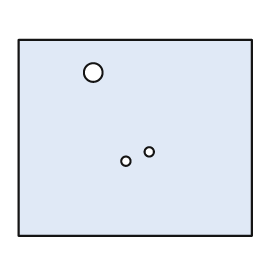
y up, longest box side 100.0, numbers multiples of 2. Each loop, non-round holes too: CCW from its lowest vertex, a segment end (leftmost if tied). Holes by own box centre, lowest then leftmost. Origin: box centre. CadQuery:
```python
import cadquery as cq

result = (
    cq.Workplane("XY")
    .moveTo(-50.0, -42.0)
    .lineTo(50.0, -42.0)
    .lineTo(50.0, 42.0)
    .lineTo(-50.0, 42.0)
    .close()
    .moveTo(-4.0, -10.0)
    .circle(2.0)
    .moveTo(6.0, -6.0)
    .circle(2.0)
    .moveTo(-18.0, 28.0)
    .circle(4.0)
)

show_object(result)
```